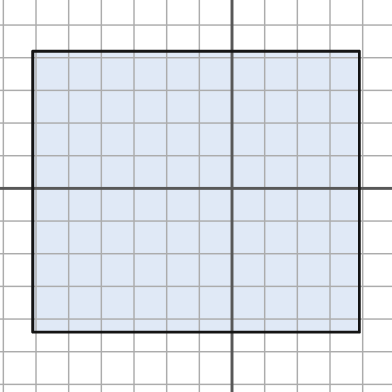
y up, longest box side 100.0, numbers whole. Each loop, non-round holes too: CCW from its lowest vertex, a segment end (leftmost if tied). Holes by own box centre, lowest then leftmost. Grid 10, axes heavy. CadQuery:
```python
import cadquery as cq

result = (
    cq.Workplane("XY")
    .moveTo(-61.0, -44.0)
    .lineTo(39.0, -44.0)
    .lineTo(39.0, 42.0)
    .lineTo(-61.0, 42.0)
    .close()
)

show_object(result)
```